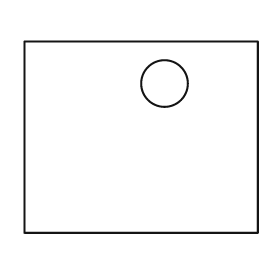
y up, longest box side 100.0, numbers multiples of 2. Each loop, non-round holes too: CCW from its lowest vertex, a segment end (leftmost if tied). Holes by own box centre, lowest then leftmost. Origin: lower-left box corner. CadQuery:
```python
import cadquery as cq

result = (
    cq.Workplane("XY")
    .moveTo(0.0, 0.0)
    .lineTo(100.0, 0.0)
    .lineTo(100.0, 82.0)
    .lineTo(0.0, 82.0)
    .close()
    .moveTo(60.0, 64.0)
    .circle(10.0)
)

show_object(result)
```